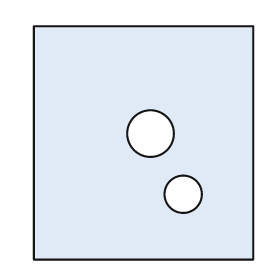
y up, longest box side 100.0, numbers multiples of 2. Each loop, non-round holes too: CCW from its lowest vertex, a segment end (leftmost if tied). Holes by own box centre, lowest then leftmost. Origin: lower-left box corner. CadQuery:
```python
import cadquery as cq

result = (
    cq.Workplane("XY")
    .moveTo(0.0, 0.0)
    .lineTo(94.0, 0.0)
    .lineTo(94.0, 100.0)
    .lineTo(0.0, 100.0)
    .close()
    .moveTo(64.0, 28.0)
    .circle(8.0)
    .moveTo(50.0, 54.0)
    .circle(10.0)
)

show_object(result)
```